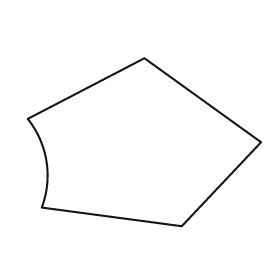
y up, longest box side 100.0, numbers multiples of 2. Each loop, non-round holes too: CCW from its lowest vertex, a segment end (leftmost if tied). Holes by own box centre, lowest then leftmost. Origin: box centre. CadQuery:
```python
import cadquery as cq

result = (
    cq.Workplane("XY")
    .moveTo(16.0, -36.0)
    .lineTo(50.0, 0.0)
    .lineTo(0.0, 36.0)
    .lineTo(-50.0, 10.0)
    .threePointArc((-42.0, -8.0), (-44.0, -28.0))
    .close()
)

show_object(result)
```